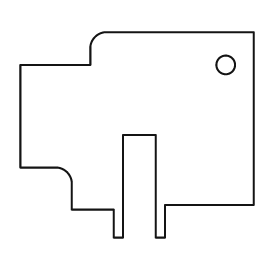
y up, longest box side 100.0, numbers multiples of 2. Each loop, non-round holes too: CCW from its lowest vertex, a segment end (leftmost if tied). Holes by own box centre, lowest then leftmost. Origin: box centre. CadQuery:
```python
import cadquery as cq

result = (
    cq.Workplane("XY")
    .moveTo(-10.0, -44.0)
    .lineTo(-6.0, -44.0)
    .lineTo(-6.0, 0.0)
    .lineTo(8.0, 0.0)
    .lineTo(8.0, -44.0)
    .lineTo(12.0, -44.0)
    .lineTo(12.0, -30.0)
    .lineTo(50.0, -30.0)
    .lineTo(50.0, 44.0)
    .lineTo(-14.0, 44.0)
    .threePointArc((-18.0, 42.0), (-20.0, 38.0))
    .lineTo(-20.0, 30.0)
    .lineTo(-50.0, 30.0)
    .lineTo(-50.0, -14.0)
    .lineTo(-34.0, -14.0)
    .threePointArc((-30.0, -16.0), (-28.0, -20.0))
    .lineTo(-28.0, -32.0)
    .lineTo(-10.0, -32.0)
    .close()
    .moveTo(38.0, 30.0)
    .circle(4.0)
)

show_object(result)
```